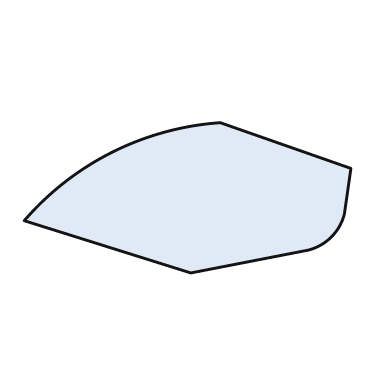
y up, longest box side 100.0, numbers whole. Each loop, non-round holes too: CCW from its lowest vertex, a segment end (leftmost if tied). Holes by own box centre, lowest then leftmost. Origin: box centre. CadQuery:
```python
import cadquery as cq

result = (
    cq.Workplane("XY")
    .moveTo(1.0, -23.0)
    .lineTo(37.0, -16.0)
    .threePointArc((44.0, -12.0), (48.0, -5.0))
    .lineTo(50.0, 9.0)
    .lineTo(10.0, 23.0)
    .threePointArc((-23.0, 14.0), (-50.0, -7.0))
    .close()
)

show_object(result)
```